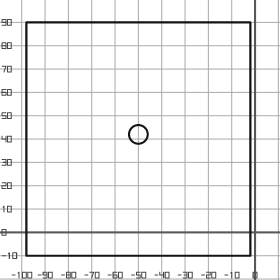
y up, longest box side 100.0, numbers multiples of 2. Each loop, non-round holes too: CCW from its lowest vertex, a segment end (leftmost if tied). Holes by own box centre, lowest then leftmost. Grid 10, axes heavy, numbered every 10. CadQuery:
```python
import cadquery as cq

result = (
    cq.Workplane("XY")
    .moveTo(-98.0, -10.0)
    .lineTo(-2.0, -10.0)
    .lineTo(-2.0, 90.0)
    .lineTo(-98.0, 90.0)
    .close()
    .moveTo(-50.0, 42.0)
    .circle(4.0)
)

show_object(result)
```